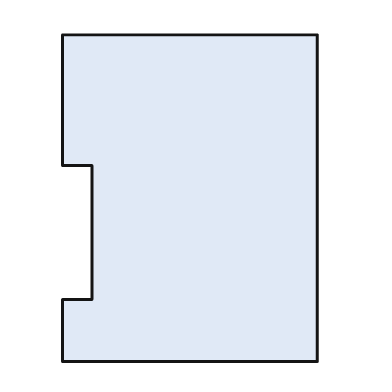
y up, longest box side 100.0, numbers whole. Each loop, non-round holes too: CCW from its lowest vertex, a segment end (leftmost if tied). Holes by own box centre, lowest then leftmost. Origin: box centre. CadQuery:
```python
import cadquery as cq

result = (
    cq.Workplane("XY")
    .moveTo(-39.0, -50.0)
    .lineTo(39.0, -50.0)
    .lineTo(39.0, 50.0)
    .lineTo(-39.0, 50.0)
    .lineTo(-39.0, 10.0)
    .lineTo(-30.0, 10.0)
    .lineTo(-30.0, -31.0)
    .lineTo(-39.0, -31.0)
    .close()
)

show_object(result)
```